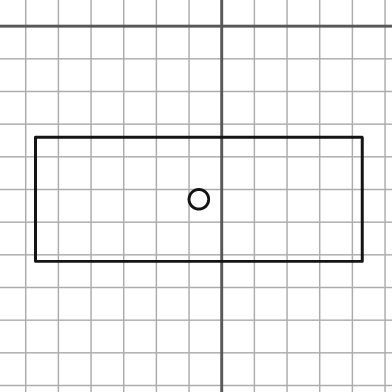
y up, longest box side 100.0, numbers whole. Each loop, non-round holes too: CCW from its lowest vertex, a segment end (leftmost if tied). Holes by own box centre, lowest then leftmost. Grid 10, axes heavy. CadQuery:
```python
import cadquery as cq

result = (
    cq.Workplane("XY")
    .moveTo(-57.0, -72.0)
    .lineTo(43.0, -72.0)
    .lineTo(43.0, -34.0)
    .lineTo(-57.0, -34.0)
    .close()
    .moveTo(-7.0, -53.0)
    .circle(3.0)
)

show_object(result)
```